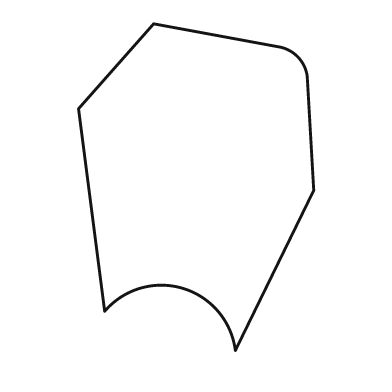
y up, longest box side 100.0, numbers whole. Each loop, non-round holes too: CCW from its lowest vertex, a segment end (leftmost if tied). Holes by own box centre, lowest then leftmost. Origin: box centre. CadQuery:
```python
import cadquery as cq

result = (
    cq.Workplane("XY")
    .moveTo(12.0, -50.0)
    .lineTo(36.0, -1.0)
    .lineTo(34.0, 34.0)
    .threePointArc((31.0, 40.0), (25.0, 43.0))
    .lineTo(-13.0, 50.0)
    .lineTo(-36.0, 24.0)
    .lineTo(-28.0, -38.0)
    .threePointArc((-4.0, -31.0), (12.0, -50.0))
    .close()
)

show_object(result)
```